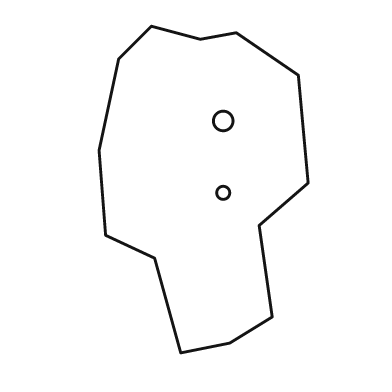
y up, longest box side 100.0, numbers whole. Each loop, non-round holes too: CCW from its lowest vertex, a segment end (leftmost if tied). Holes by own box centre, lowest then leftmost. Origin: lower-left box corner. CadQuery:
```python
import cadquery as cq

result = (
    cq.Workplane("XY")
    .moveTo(25.0, 0.0)
    .lineTo(40.0, 3.0)
    .lineTo(53.0, 11.0)
    .lineTo(49.0, 39.0)
    .lineTo(64.0, 52.0)
    .lineTo(61.0, 85.0)
    .lineTo(42.0, 98.0)
    .lineTo(31.0, 96.0)
    .lineTo(16.0, 100.0)
    .lineTo(6.0, 90.0)
    .lineTo(0.0, 62.0)
    .lineTo(2.0, 36.0)
    .lineTo(17.0, 29.0)
    .close()
    .moveTo(38.0, 49.0)
    .circle(2.0)
    .moveTo(38.0, 71.0)
    .circle(3.0)
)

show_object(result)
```